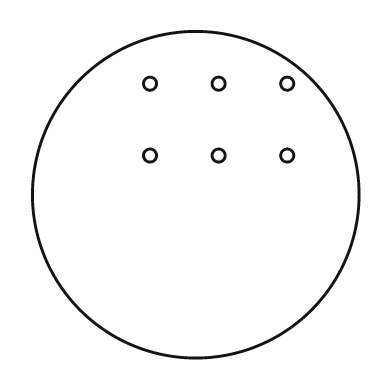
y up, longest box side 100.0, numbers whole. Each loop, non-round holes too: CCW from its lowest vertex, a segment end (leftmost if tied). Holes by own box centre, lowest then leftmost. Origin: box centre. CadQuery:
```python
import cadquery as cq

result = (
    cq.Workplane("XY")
    .moveTo(0.0, 0.0)
    .circle(50.0)
    .moveTo(-14.0, 12.0)
    .circle(2.0)
    .moveTo(7.0, 12.0)
    .circle(2.0)
    .moveTo(28.0, 12.0)
    .circle(2.0)
    .moveTo(-14.0, 34.0)
    .circle(2.0)
    .moveTo(7.0, 34.0)
    .circle(2.0)
    .moveTo(28.0, 34.0)
    .circle(2.0)
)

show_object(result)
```